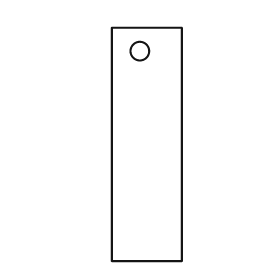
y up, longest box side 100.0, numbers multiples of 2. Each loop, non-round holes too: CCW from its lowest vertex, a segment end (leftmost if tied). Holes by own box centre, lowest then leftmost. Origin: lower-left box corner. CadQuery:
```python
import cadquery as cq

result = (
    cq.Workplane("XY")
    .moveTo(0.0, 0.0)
    .lineTo(30.0, 0.0)
    .lineTo(30.0, 100.0)
    .lineTo(0.0, 100.0)
    .close()
    .moveTo(12.0, 90.0)
    .circle(4.0)
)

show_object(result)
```